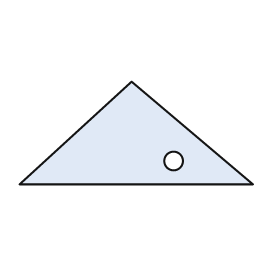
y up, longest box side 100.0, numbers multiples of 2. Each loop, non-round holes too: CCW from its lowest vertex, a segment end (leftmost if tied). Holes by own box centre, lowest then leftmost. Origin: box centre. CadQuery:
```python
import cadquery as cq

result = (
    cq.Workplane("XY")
    .moveTo(-50.0, -22.0)
    .lineTo(50.0, -22.0)
    .lineTo(-2.0, 22.0)
    .close()
    .moveTo(16.0, -12.0)
    .circle(4.0)
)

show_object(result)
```